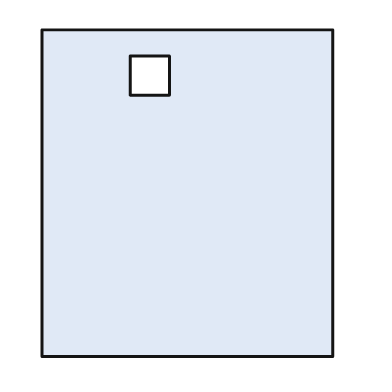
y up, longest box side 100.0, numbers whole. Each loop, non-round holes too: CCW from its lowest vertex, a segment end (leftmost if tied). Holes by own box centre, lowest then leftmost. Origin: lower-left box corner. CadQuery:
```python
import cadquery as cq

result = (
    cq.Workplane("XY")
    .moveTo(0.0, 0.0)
    .lineTo(89.0, 0.0)
    .lineTo(89.0, 100.0)
    .lineTo(0.0, 100.0)
    .close()
    .moveTo(27.0, 80.0)
    .lineTo(39.0, 80.0)
    .lineTo(39.0, 92.0)
    .lineTo(27.0, 92.0)
    .close()
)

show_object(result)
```